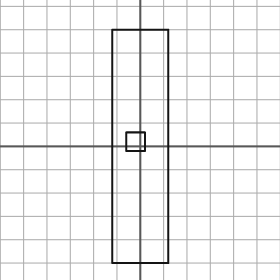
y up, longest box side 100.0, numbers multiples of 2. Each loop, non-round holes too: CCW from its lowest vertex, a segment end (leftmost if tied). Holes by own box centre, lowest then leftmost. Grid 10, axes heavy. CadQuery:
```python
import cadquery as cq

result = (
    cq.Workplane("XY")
    .moveTo(-12.0, -50.0)
    .lineTo(12.0, -50.0)
    .lineTo(12.0, 50.0)
    .lineTo(-12.0, 50.0)
    .close()
    .moveTo(-6.0, -2.0)
    .lineTo(2.0, -2.0)
    .lineTo(2.0, 6.0)
    .lineTo(-6.0, 6.0)
    .close()
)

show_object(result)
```